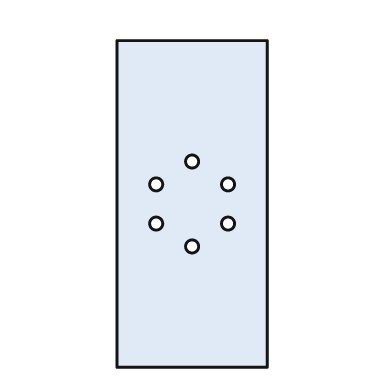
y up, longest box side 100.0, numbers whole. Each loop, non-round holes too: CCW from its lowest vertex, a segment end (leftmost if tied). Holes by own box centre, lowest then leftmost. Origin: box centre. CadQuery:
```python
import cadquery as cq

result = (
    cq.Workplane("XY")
    .moveTo(-23.0, -50.0)
    .lineTo(23.0, -50.0)
    .lineTo(23.0, 50.0)
    .lineTo(-23.0, 50.0)
    .close()
    .moveTo(0.0, -13.0)
    .circle(2.0)
    .moveTo(-11.0, -6.0)
    .circle(2.0)
    .moveTo(11.0, -6.0)
    .circle(2.0)
    .moveTo(-11.0, 6.0)
    .circle(2.0)
    .moveTo(11.0, 6.0)
    .circle(2.0)
    .moveTo(0.0, 13.0)
    .circle(2.0)
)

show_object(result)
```